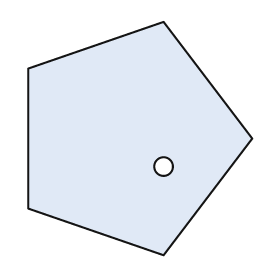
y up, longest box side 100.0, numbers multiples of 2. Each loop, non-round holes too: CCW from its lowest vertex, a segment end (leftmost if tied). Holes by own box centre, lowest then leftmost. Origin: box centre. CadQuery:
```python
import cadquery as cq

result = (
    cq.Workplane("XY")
    .moveTo(10.0, -50.0)
    .lineTo(48.0, 0.0)
    .lineTo(10.0, 50.0)
    .lineTo(-48.0, 30.0)
    .lineTo(-48.0, -30.0)
    .close()
    .moveTo(10.0, -12.0)
    .circle(4.0)
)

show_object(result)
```